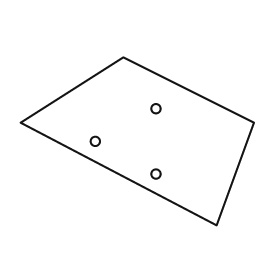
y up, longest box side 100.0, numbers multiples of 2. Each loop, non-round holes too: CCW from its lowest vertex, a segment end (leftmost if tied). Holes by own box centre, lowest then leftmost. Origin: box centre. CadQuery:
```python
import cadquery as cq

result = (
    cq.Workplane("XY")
    .moveTo(34.0, -36.0)
    .lineTo(50.0, 8.0)
    .lineTo(-6.0, 36.0)
    .lineTo(-50.0, 8.0)
    .close()
    .moveTo(8.0, -14.0)
    .circle(2.0)
    .moveTo(-18.0, 0.0)
    .circle(2.0)
    .moveTo(8.0, 14.0)
    .circle(2.0)
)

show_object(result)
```